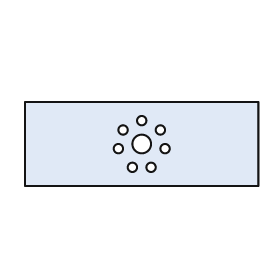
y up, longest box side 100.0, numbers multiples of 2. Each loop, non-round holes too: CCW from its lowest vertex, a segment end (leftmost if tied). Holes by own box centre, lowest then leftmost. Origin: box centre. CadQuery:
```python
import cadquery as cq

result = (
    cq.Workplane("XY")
    .moveTo(-50.0, -18.0)
    .lineTo(50.0, -18.0)
    .lineTo(50.0, 18.0)
    .lineTo(-50.0, 18.0)
    .close()
    .moveTo(-4.0, -10.0)
    .circle(2.0)
    .moveTo(4.0, -10.0)
    .circle(2.0)
    .moveTo(-10.0, -2.0)
    .circle(2.0)
    .moveTo(10.0, -2.0)
    .circle(2.0)
    .moveTo(0.0, 0.0)
    .circle(4.0)
    .moveTo(-8.0, 6.0)
    .circle(2.0)
    .moveTo(8.0, 6.0)
    .circle(2.0)
    .moveTo(0.0, 10.0)
    .circle(2.0)
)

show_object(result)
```